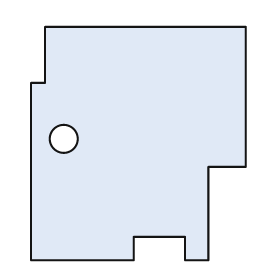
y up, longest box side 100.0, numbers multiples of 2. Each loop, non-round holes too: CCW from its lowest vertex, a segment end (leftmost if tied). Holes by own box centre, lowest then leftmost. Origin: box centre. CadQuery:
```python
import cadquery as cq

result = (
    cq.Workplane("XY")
    .moveTo(-46.0, -50.0)
    .lineTo(-2.0, -50.0)
    .lineTo(-2.0, -40.0)
    .lineTo(20.0, -40.0)
    .lineTo(20.0, -50.0)
    .lineTo(30.0, -50.0)
    .lineTo(30.0, -10.0)
    .lineTo(46.0, -10.0)
    .lineTo(46.0, 50.0)
    .lineTo(-40.0, 50.0)
    .lineTo(-40.0, 26.0)
    .lineTo(-46.0, 26.0)
    .close()
    .moveTo(-32.0, 2.0)
    .circle(6.0)
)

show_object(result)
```